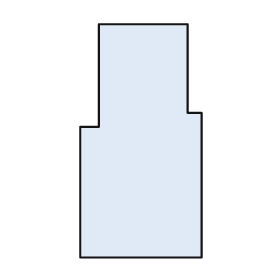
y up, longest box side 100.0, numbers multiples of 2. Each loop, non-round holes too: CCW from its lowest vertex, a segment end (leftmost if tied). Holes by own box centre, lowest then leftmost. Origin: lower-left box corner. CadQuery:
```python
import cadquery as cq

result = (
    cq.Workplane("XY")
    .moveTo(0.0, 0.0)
    .lineTo(52.0, 0.0)
    .lineTo(52.0, 62.0)
    .lineTo(46.0, 62.0)
    .lineTo(46.0, 100.0)
    .lineTo(8.0, 100.0)
    .lineTo(8.0, 56.0)
    .lineTo(0.0, 56.0)
    .close()
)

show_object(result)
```